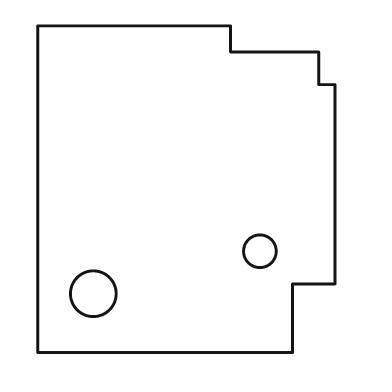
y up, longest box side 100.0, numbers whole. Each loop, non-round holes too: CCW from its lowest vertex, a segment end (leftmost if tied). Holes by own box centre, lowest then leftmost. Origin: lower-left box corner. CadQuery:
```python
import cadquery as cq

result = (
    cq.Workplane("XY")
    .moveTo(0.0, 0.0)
    .lineTo(78.0, 0.0)
    .lineTo(78.0, 21.0)
    .lineTo(91.0, 21.0)
    .lineTo(91.0, 82.0)
    .lineTo(86.0, 82.0)
    .lineTo(86.0, 92.0)
    .lineTo(59.0, 92.0)
    .lineTo(59.0, 100.0)
    .lineTo(0.0, 100.0)
    .close()
    .moveTo(17.0, 18.0)
    .circle(7.0)
    .moveTo(68.0, 31.0)
    .circle(5.0)
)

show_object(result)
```